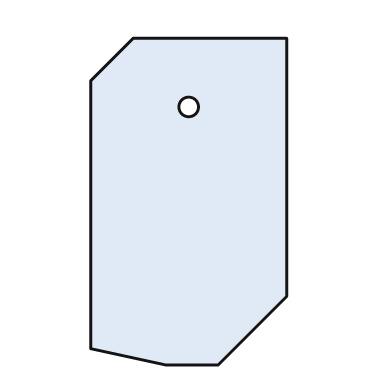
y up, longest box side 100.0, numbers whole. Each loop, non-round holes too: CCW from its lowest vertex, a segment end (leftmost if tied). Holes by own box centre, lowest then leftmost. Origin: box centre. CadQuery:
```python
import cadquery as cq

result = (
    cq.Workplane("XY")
    .moveTo(-7.0, -50.0)
    .lineTo(9.0, -50.0)
    .lineTo(30.0, -29.0)
    .lineTo(30.0, 50.0)
    .lineTo(-17.0, 50.0)
    .lineTo(-30.0, 37.0)
    .lineTo(-30.0, -45.0)
    .close()
    .moveTo(0.0, 29.0)
    .circle(3.0)
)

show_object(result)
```